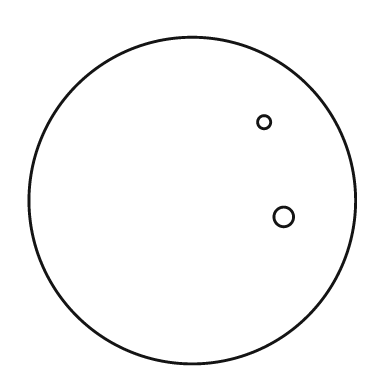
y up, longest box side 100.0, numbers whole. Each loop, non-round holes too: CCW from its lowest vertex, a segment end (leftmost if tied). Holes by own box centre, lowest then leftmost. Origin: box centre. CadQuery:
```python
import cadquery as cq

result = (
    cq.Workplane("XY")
    .moveTo(0.0, 0.0)
    .circle(50.0)
    .moveTo(28.0, -5.0)
    .circle(3.0)
    .moveTo(22.0, 24.0)
    .circle(2.0)
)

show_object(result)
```